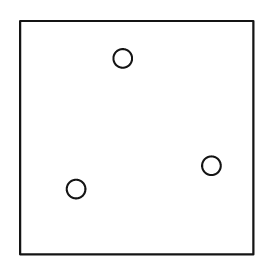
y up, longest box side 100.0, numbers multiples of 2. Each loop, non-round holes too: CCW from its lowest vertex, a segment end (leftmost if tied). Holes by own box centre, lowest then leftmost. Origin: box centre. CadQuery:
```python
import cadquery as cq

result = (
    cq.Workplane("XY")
    .moveTo(-50.0, -50.0)
    .lineTo(50.0, -50.0)
    .lineTo(50.0, 50.0)
    .lineTo(-50.0, 50.0)
    .close()
    .moveTo(-26.0, -22.0)
    .circle(4.0)
    .moveTo(32.0, -12.0)
    .circle(4.0)
    .moveTo(-6.0, 34.0)
    .circle(4.0)
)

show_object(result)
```